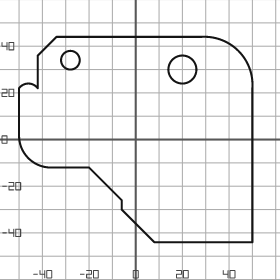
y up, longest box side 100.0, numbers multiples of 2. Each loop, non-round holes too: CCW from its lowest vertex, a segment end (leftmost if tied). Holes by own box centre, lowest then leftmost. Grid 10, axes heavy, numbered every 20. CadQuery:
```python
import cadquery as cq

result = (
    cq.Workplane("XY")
    .moveTo(8.0, -44.0)
    .lineTo(50.0, -44.0)
    .lineTo(50.0, 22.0)
    .threePointArc((44.0, 38.0), (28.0, 44.0))
    .lineTo(-34.0, 44.0)
    .lineTo(-42.0, 36.0)
    .lineTo(-42.0, 22.0)
    .threePointArc((-46.0, 24.0), (-50.0, 22.0))
    .lineTo(-50.0, 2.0)
    .threePointArc((-46.0, -8.0), (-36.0, -12.0))
    .lineTo(-20.0, -12.0)
    .lineTo(-6.0, -26.0)
    .lineTo(-6.0, -30.0)
    .close()
    .moveTo(20.0, 30.0)
    .circle(6.0)
    .moveTo(-28.0, 34.0)
    .circle(4.0)
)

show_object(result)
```